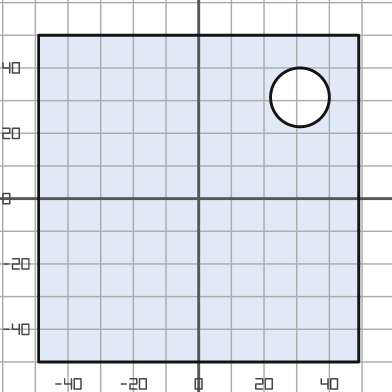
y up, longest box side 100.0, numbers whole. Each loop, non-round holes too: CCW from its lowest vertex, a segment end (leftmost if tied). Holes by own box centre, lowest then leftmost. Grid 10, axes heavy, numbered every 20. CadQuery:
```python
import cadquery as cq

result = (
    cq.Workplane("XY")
    .moveTo(-49.0, -50.0)
    .lineTo(49.0, -50.0)
    .lineTo(49.0, 50.0)
    .lineTo(-49.0, 50.0)
    .close()
    .moveTo(31.0, 31.0)
    .circle(9.0)
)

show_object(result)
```